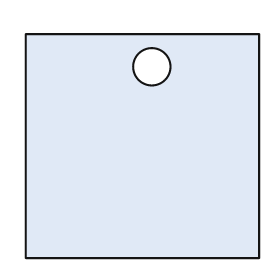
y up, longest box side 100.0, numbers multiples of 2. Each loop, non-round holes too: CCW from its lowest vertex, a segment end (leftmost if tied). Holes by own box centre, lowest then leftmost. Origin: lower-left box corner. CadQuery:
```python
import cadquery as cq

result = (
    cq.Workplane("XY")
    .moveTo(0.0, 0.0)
    .lineTo(100.0, 0.0)
    .lineTo(100.0, 96.0)
    .lineTo(0.0, 96.0)
    .close()
    .moveTo(54.0, 82.0)
    .circle(8.0)
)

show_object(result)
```